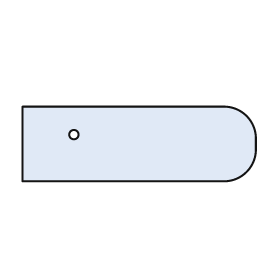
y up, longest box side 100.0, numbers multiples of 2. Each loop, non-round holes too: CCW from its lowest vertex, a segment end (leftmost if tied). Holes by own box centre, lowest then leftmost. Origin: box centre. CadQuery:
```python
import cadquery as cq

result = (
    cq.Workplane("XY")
    .moveTo(-50.0, -16.0)
    .lineTo(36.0, -16.0)
    .threePointArc((46.0, -12.0), (50.0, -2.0))
    .lineTo(50.0, 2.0)
    .threePointArc((46.0, 12.0), (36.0, 16.0))
    .lineTo(-50.0, 16.0)
    .close()
    .moveTo(-28.0, 4.0)
    .circle(2.0)
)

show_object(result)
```